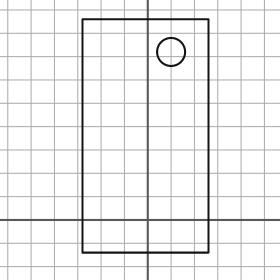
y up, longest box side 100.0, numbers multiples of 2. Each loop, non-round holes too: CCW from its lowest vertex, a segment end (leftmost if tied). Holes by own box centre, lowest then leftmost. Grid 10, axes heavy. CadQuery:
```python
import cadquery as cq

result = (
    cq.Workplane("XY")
    .moveTo(-28.0, -14.0)
    .lineTo(26.0, -14.0)
    .lineTo(26.0, 86.0)
    .lineTo(-28.0, 86.0)
    .close()
    .moveTo(10.0, 72.0)
    .circle(6.0)
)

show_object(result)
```